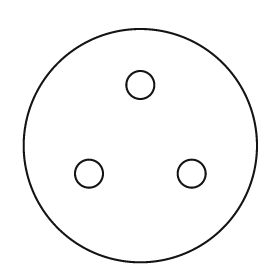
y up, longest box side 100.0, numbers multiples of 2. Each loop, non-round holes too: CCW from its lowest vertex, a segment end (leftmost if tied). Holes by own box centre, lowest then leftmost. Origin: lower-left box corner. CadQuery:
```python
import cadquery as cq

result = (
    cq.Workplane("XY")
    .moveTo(50.0, 50.0)
    .circle(50.0)
    .moveTo(28.0, 38.0)
    .circle(6.0)
    .moveTo(72.0, 38.0)
    .circle(6.0)
    .moveTo(50.0, 76.0)
    .circle(6.0)
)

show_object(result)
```